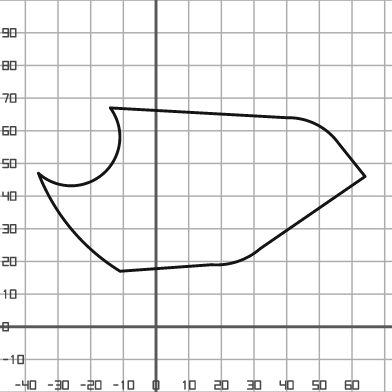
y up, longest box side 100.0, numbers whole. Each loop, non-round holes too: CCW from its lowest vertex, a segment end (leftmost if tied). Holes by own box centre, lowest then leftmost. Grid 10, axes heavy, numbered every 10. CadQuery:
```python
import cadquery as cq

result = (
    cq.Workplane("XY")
    .moveTo(-11.0, 17.0)
    .lineTo(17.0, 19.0)
    .threePointArc((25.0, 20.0), (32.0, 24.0))
    .lineTo(64.0, 46.0)
    .lineTo(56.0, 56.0)
    .threePointArc((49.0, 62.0), (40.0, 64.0))
    .lineTo(-14.0, 67.0)
    .threePointArc((-16.0, 47.0), (-36.0, 47.0))
    .threePointArc((-26.0, 30.0), (-11.0, 17.0))
    .close()
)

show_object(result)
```